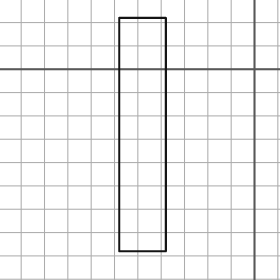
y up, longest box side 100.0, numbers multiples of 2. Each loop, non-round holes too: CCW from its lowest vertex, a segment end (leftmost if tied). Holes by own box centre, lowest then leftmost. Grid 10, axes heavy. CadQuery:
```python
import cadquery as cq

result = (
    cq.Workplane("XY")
    .moveTo(-58.0, -78.0)
    .lineTo(-38.0, -78.0)
    .lineTo(-38.0, 22.0)
    .lineTo(-58.0, 22.0)
    .close()
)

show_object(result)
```